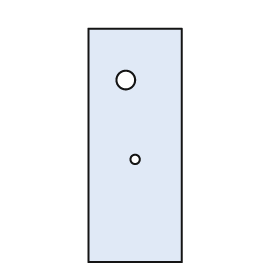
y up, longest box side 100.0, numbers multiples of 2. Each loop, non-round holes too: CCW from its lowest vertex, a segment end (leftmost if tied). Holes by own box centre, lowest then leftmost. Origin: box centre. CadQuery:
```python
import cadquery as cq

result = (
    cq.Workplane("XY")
    .moveTo(-20.0, -50.0)
    .lineTo(20.0, -50.0)
    .lineTo(20.0, 50.0)
    .lineTo(-20.0, 50.0)
    .close()
    .moveTo(0.0, -6.0)
    .circle(2.0)
    .moveTo(-4.0, 28.0)
    .circle(4.0)
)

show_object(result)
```